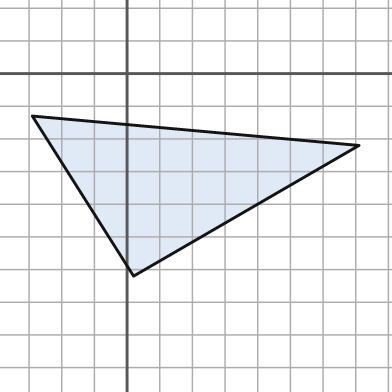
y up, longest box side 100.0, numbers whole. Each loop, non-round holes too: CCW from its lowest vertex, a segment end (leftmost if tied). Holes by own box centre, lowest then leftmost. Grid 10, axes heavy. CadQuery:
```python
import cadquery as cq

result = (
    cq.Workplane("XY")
    .moveTo(2.0, -62.0)
    .lineTo(71.0, -22.0)
    .lineTo(-29.0, -13.0)
    .close()
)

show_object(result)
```